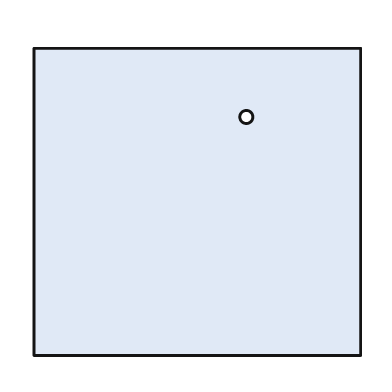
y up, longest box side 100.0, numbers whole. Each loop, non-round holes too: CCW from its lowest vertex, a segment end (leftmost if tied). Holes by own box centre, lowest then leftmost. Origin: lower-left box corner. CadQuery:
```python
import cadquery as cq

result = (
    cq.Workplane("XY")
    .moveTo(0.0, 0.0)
    .lineTo(100.0, 0.0)
    .lineTo(100.0, 94.0)
    .lineTo(0.0, 94.0)
    .close()
    .moveTo(65.0, 73.0)
    .circle(2.0)
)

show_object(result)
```